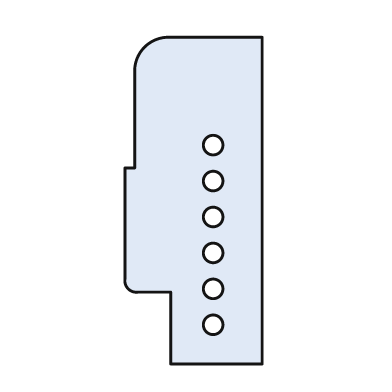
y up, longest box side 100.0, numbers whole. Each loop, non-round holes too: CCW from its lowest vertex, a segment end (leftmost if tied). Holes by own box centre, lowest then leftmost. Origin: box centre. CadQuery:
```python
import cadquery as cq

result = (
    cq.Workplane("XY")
    .moveTo(-7.0, -50.0)
    .lineTo(21.0, -50.0)
    .lineTo(21.0, 50.0)
    .lineTo(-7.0, 50.0)
    .threePointArc((-15.0, 47.0), (-18.0, 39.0))
    .lineTo(-18.0, 10.0)
    .lineTo(-21.0, 10.0)
    .lineTo(-21.0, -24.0)
    .threePointArc((-20.0, -27.0), (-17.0, -28.0))
    .lineTo(-7.0, -28.0)
    .close()
    .moveTo(6.0, -38.0)
    .circle(3.0)
    .moveTo(6.0, -27.0)
    .circle(3.0)
    .moveTo(6.0, -16.0)
    .circle(3.0)
    .moveTo(6.0, -5.0)
    .circle(3.0)
    .moveTo(6.0, 6.0)
    .circle(3.0)
    .moveTo(6.0, 17.0)
    .circle(3.0)
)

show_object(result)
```